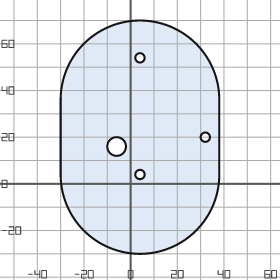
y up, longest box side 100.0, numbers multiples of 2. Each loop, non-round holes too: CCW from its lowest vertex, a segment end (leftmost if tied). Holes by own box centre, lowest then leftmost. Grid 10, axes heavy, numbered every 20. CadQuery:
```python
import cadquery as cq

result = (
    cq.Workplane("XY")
    .moveTo(-30.0, 4.0)
    .threePointArc((4.0, -30.0), (38.0, 4.0))
    .lineTo(38.0, 36.0)
    .threePointArc((4.0, 70.0), (-30.0, 36.0))
    .close()
    .moveTo(4.0, 4.0)
    .circle(2.0)
    .moveTo(-6.0, 16.0)
    .circle(4.0)
    .moveTo(32.0, 20.0)
    .circle(2.0)
    .moveTo(4.0, 54.0)
    .circle(2.0)
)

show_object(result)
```